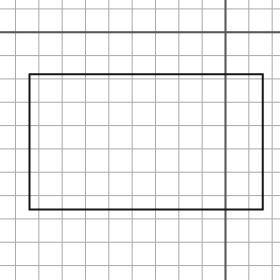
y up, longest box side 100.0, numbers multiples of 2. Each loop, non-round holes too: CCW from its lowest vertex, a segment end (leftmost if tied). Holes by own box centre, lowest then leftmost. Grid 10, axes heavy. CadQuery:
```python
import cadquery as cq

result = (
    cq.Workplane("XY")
    .moveTo(-84.0, -76.0)
    .lineTo(16.0, -76.0)
    .lineTo(16.0, -18.0)
    .lineTo(-84.0, -18.0)
    .close()
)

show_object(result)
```